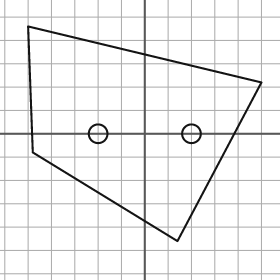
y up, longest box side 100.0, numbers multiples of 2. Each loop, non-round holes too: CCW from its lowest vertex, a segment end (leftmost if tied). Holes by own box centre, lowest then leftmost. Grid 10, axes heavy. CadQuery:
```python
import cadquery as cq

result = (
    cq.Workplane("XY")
    .moveTo(14.0, -46.0)
    .lineTo(50.0, 22.0)
    .lineTo(-50.0, 46.0)
    .lineTo(-48.0, -8.0)
    .close()
    .moveTo(-20.0, 0.0)
    .circle(4.0)
    .moveTo(20.0, 0.0)
    .circle(4.0)
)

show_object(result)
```